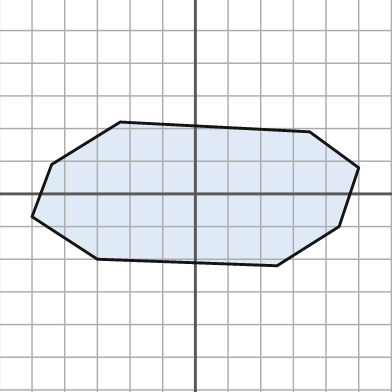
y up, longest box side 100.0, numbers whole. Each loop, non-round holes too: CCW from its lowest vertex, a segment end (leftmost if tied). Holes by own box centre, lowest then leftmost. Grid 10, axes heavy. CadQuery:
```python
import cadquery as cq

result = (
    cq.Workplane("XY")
    .moveTo(25.0, -22.0)
    .lineTo(44.0, -10.0)
    .lineTo(50.0, 8.0)
    .lineTo(35.0, 19.0)
    .lineTo(-23.0, 22.0)
    .lineTo(-44.0, 9.0)
    .lineTo(-50.0, -7.0)
    .lineTo(-30.0, -20.0)
    .close()
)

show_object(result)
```